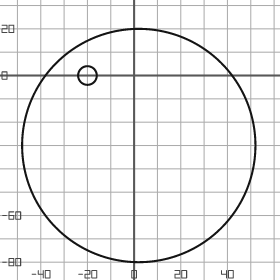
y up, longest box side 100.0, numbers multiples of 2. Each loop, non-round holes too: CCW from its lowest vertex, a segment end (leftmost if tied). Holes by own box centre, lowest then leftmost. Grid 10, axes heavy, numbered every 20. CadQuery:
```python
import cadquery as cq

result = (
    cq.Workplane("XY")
    .moveTo(2.0, -30.0)
    .circle(50.0)
    .moveTo(-20.0, 0.0)
    .circle(4.0)
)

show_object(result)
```